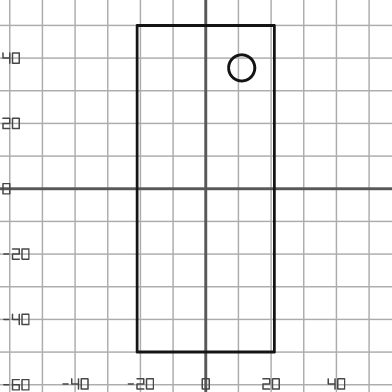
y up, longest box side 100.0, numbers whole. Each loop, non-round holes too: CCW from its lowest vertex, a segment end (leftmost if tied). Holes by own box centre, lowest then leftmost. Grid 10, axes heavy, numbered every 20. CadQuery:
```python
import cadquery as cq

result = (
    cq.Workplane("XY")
    .moveTo(-21.0, -50.0)
    .lineTo(21.0, -50.0)
    .lineTo(21.0, 50.0)
    .lineTo(-21.0, 50.0)
    .close()
    .moveTo(11.0, 37.0)
    .circle(4.0)
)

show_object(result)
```